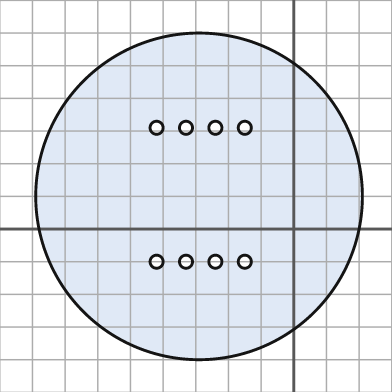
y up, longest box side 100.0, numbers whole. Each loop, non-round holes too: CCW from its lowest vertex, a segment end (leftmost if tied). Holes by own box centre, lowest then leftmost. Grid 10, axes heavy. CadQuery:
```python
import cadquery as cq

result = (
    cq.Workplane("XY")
    .moveTo(-29.0, 10.0)
    .circle(50.0)
    .moveTo(-42.0, -10.0)
    .circle(2.0)
    .moveTo(-33.0, -10.0)
    .circle(2.0)
    .moveTo(-24.0, -10.0)
    .circle(2.0)
    .moveTo(-15.0, -10.0)
    .circle(2.0)
    .moveTo(-42.0, 31.0)
    .circle(2.0)
    .moveTo(-33.0, 31.0)
    .circle(2.0)
    .moveTo(-24.0, 31.0)
    .circle(2.0)
    .moveTo(-15.0, 31.0)
    .circle(2.0)
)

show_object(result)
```